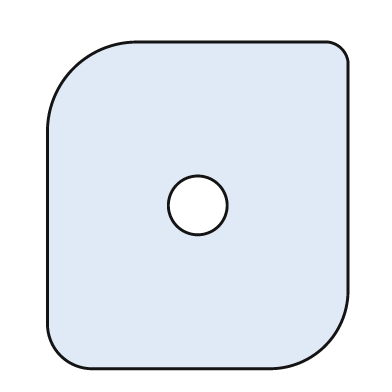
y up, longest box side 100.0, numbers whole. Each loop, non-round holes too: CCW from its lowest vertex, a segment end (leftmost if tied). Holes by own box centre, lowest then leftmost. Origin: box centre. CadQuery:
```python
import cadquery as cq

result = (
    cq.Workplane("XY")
    .moveTo(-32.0, -50.0)
    .lineTo(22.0, -50.0)
    .threePointArc((39.0, -43.0), (46.0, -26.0))
    .lineTo(46.0, 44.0)
    .threePointArc((44.0, 48.0), (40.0, 50.0))
    .lineTo(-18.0, 50.0)
    .threePointArc((-38.0, 42.0), (-46.0, 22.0))
    .lineTo(-46.0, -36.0)
    .threePointArc((-42.0, -46.0), (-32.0, -50.0))
    .close()
    .moveTo(0.0, 0.0)
    .circle(9.0)
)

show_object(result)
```